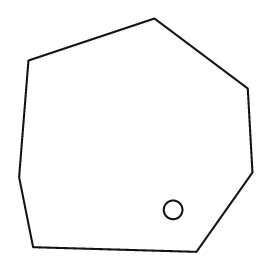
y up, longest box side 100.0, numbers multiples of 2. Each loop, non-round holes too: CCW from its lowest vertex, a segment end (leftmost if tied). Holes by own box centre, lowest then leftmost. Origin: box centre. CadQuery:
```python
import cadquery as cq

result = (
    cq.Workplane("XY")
    .moveTo(26.0, -50.0)
    .lineTo(50.0, -16.0)
    .lineTo(48.0, 20.0)
    .lineTo(8.0, 50.0)
    .lineTo(-46.0, 32.0)
    .lineTo(-50.0, -18.0)
    .lineTo(-44.0, -48.0)
    .close()
    .moveTo(16.0, -32.0)
    .circle(4.0)
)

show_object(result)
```